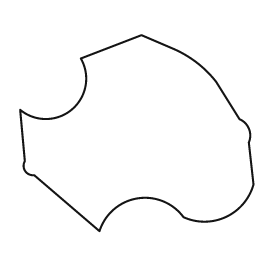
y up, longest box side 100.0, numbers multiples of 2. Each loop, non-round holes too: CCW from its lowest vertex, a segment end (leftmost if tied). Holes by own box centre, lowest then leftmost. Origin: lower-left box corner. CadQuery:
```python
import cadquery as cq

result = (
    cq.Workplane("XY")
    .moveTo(34.0, 0.0)
    .threePointArc((50.0, 14.0), (70.0, 6.0))
    .threePointArc((88.0, 6.0), (100.0, 20.0))
    .lineTo(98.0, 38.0)
    .threePointArc((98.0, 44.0), (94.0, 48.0))
    .lineTo(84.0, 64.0)
    .threePointArc((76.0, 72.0), (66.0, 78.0))
    .lineTo(52.0, 84.0)
    .lineTo(26.0, 74.0)
    .threePointArc((22.0, 52.0), (0.0, 52.0))
    .lineTo(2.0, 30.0)
    .threePointArc((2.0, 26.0), (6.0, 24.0))
    .close()
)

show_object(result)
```